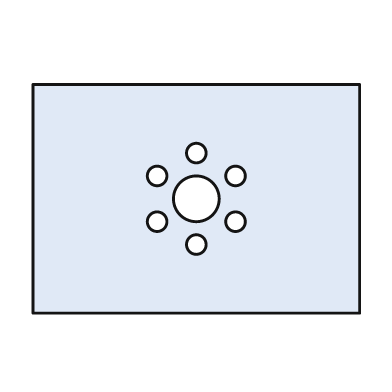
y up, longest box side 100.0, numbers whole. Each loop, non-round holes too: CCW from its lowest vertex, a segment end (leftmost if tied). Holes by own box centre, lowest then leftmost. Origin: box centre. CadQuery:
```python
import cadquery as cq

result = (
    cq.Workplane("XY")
    .moveTo(-50.0, -35.0)
    .lineTo(50.0, -35.0)
    .lineTo(50.0, 35.0)
    .lineTo(-50.0, 35.0)
    .close()
    .moveTo(0.0, -14.0)
    .circle(3.0)
    .moveTo(-12.0, -7.0)
    .circle(3.0)
    .moveTo(12.0, -7.0)
    .circle(3.0)
    .moveTo(0.0, 0.0)
    .circle(7.0)
    .moveTo(-12.0, 7.0)
    .circle(3.0)
    .moveTo(12.0, 7.0)
    .circle(3.0)
    .moveTo(0.0, 14.0)
    .circle(3.0)
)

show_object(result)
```